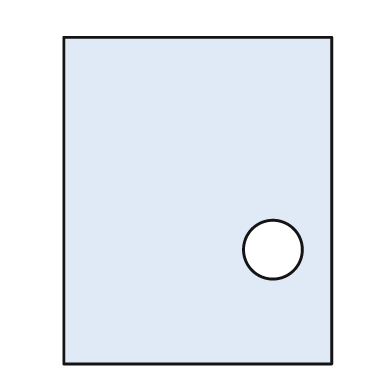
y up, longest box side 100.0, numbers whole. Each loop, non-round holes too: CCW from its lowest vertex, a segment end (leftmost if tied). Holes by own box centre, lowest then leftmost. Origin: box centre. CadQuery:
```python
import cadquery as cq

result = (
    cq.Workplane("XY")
    .moveTo(-41.0, -50.0)
    .lineTo(41.0, -50.0)
    .lineTo(41.0, 50.0)
    .lineTo(-41.0, 50.0)
    .close()
    .moveTo(23.0, -15.0)
    .circle(9.0)
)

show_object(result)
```